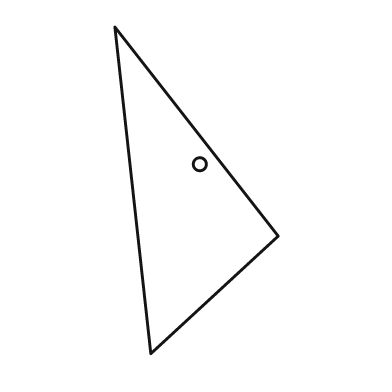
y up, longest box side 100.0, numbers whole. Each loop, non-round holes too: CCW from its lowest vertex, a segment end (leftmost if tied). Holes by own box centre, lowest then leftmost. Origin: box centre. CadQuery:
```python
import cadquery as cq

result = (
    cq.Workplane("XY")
    .moveTo(-14.0, -50.0)
    .lineTo(25.0, -14.0)
    .lineTo(-25.0, 50.0)
    .close()
    .moveTo(1.0, 8.0)
    .circle(2.0)
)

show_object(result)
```